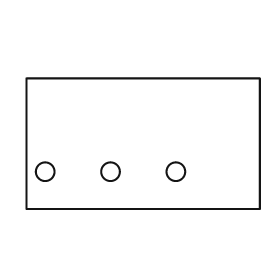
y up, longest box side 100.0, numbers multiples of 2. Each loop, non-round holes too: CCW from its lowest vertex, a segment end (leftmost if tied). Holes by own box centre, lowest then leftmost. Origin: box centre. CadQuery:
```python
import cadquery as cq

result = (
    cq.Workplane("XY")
    .moveTo(-50.0, -28.0)
    .lineTo(50.0, -28.0)
    .lineTo(50.0, 28.0)
    .lineTo(-50.0, 28.0)
    .close()
    .moveTo(-42.0, -12.0)
    .circle(4.0)
    .moveTo(-14.0, -12.0)
    .circle(4.0)
    .moveTo(14.0, -12.0)
    .circle(4.0)
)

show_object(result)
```